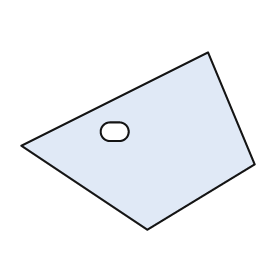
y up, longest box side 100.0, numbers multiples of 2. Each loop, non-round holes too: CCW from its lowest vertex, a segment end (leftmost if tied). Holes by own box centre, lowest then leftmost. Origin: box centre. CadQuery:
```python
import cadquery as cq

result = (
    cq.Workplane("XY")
    .moveTo(4.0, -38.0)
    .lineTo(50.0, -10.0)
    .lineTo(30.0, 38.0)
    .lineTo(-50.0, -2.0)
    .close()
    .moveTo(-12.0, 0.0)
    .lineTo(-8.0, 0.0)
    .threePointArc((-4.0, 4.0), (-8.0, 8.0))
    .lineTo(-12.0, 8.0)
    .threePointArc((-16.0, 4.0), (-12.0, 0.0))
    .close()
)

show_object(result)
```